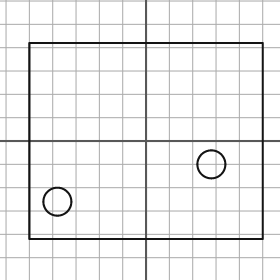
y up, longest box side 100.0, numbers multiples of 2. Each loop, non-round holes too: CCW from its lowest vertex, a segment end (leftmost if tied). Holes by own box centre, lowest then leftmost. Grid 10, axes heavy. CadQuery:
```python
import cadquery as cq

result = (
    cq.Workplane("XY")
    .moveTo(-50.0, -42.0)
    .lineTo(50.0, -42.0)
    .lineTo(50.0, 42.0)
    .lineTo(-50.0, 42.0)
    .close()
    .moveTo(-38.0, -26.0)
    .circle(6.0)
    .moveTo(28.0, -10.0)
    .circle(6.0)
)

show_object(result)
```